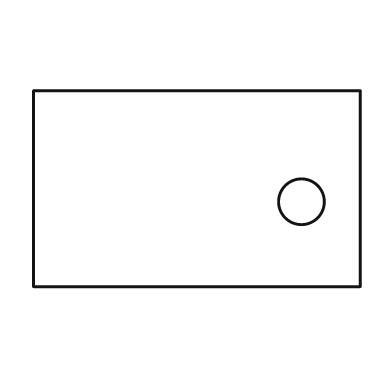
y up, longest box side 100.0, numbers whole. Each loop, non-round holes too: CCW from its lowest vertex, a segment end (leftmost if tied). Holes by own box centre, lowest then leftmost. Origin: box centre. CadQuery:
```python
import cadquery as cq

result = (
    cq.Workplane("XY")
    .moveTo(-50.0, -30.0)
    .lineTo(50.0, -30.0)
    .lineTo(50.0, 30.0)
    .lineTo(-50.0, 30.0)
    .close()
    .moveTo(32.0, -4.0)
    .circle(7.0)
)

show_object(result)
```